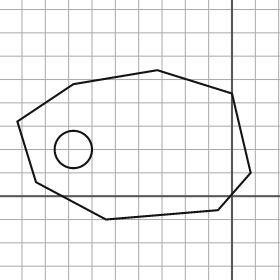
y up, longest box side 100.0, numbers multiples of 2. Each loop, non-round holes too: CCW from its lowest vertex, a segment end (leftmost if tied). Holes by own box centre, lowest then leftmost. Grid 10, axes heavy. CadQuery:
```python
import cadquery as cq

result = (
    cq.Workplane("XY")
    .moveTo(-54.0, -10.0)
    .lineTo(-6.0, -6.0)
    .lineTo(8.0, 10.0)
    .lineTo(0.0, 44.0)
    .lineTo(-32.0, 54.0)
    .lineTo(-68.0, 48.0)
    .lineTo(-92.0, 32.0)
    .lineTo(-84.0, 6.0)
    .close()
    .moveTo(-68.0, 20.0)
    .circle(8.0)
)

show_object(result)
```